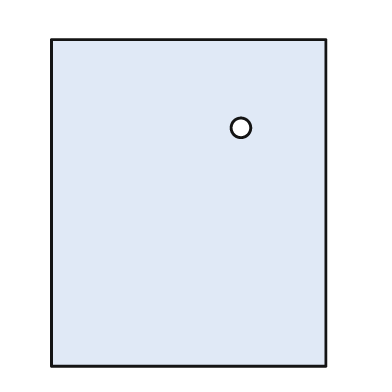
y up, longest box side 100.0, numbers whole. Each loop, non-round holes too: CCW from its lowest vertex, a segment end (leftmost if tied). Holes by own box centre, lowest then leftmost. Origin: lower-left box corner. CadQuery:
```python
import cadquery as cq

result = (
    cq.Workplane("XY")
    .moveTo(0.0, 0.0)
    .lineTo(84.0, 0.0)
    .lineTo(84.0, 100.0)
    .lineTo(0.0, 100.0)
    .close()
    .moveTo(58.0, 73.0)
    .circle(3.0)
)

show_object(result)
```